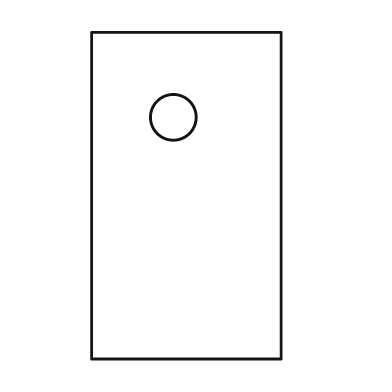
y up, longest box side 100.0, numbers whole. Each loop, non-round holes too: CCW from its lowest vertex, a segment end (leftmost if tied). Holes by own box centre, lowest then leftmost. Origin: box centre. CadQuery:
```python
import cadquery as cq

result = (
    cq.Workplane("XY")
    .moveTo(-29.0, -50.0)
    .lineTo(29.0, -50.0)
    .lineTo(29.0, 50.0)
    .lineTo(-29.0, 50.0)
    .close()
    .moveTo(-4.0, 24.0)
    .circle(7.0)
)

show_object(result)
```